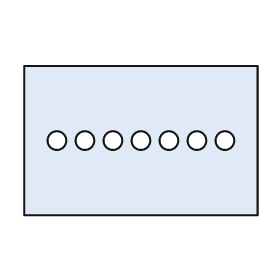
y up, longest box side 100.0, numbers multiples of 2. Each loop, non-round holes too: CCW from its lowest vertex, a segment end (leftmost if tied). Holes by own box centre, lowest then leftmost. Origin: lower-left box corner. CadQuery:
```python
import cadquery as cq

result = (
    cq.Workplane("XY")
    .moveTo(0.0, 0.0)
    .lineTo(100.0, 0.0)
    .lineTo(100.0, 64.0)
    .lineTo(0.0, 64.0)
    .close()
    .moveTo(14.0, 32.0)
    .circle(4.0)
    .moveTo(26.0, 32.0)
    .circle(4.0)
    .moveTo(38.0, 32.0)
    .circle(4.0)
    .moveTo(50.0, 32.0)
    .circle(4.0)
    .moveTo(62.0, 32.0)
    .circle(4.0)
    .moveTo(74.0, 32.0)
    .circle(4.0)
    .moveTo(86.0, 32.0)
    .circle(4.0)
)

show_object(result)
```